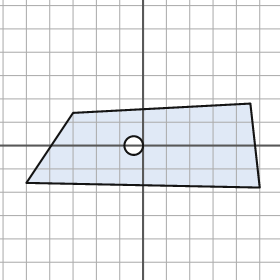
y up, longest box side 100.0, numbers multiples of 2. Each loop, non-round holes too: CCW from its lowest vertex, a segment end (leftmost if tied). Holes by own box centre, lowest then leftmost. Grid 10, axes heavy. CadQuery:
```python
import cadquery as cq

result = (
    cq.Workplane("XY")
    .moveTo(50.0, -18.0)
    .lineTo(46.0, 18.0)
    .lineTo(-30.0, 14.0)
    .lineTo(-50.0, -16.0)
    .close()
    .moveTo(-4.0, 0.0)
    .circle(4.0)
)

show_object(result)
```